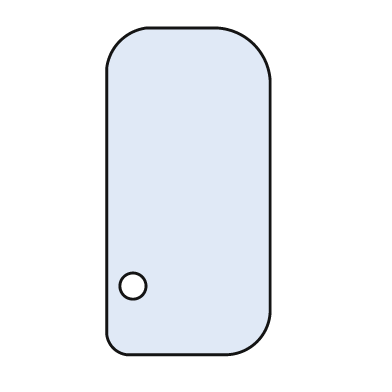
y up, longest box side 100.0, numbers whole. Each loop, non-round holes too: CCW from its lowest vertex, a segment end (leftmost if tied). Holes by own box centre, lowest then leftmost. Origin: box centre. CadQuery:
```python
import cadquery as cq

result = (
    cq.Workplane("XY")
    .moveTo(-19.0, -50.0)
    .lineTo(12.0, -50.0)
    .threePointArc((21.0, -46.0), (25.0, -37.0))
    .lineTo(25.0, 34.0)
    .threePointArc((20.0, 45.0), (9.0, 50.0))
    .lineTo(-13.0, 50.0)
    .threePointArc((-21.0, 46.0), (-25.0, 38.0))
    .lineTo(-25.0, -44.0)
    .threePointArc((-23.0, -48.0), (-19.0, -50.0))
    .close()
    .moveTo(-17.0, -29.0)
    .circle(4.0)
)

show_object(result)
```